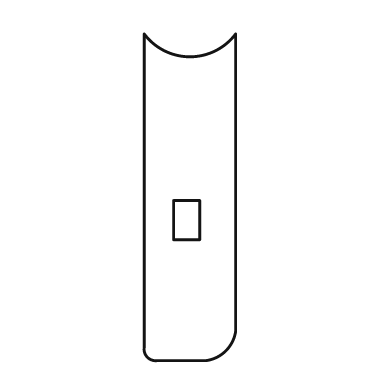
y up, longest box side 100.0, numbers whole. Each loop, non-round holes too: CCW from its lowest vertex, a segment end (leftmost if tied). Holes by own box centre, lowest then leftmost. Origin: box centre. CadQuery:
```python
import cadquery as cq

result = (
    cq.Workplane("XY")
    .moveTo(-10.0, -50.0)
    .lineTo(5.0, -50.0)
    .threePointArc((11.0, -47.0), (14.0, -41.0))
    .lineTo(14.0, 50.0)
    .threePointArc((0.0, 43.0), (-14.0, 50.0))
    .lineTo(-14.0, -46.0)
    .threePointArc((-13.0, -49.0), (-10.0, -50.0))
    .close()
    .moveTo(-5.0, -13.0)
    .lineTo(3.0, -13.0)
    .lineTo(3.0, -1.0)
    .lineTo(-5.0, -1.0)
    .close()
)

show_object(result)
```